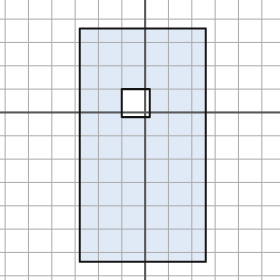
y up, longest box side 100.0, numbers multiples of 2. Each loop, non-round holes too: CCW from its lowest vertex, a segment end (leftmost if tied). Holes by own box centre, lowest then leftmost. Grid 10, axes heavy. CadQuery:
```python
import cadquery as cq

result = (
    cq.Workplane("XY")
    .moveTo(-28.0, -64.0)
    .lineTo(26.0, -64.0)
    .lineTo(26.0, 36.0)
    .lineTo(-28.0, 36.0)
    .close()
    .moveTo(-10.0, -2.0)
    .lineTo(2.0, -2.0)
    .lineTo(2.0, 10.0)
    .lineTo(-10.0, 10.0)
    .close()
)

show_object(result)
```